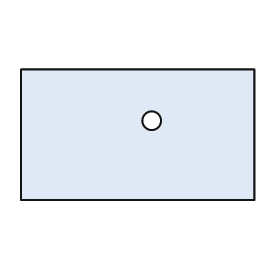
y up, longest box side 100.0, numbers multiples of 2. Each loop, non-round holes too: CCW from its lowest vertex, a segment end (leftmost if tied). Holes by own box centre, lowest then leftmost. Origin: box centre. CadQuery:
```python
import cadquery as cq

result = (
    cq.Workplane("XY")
    .moveTo(-50.0, -28.0)
    .lineTo(50.0, -28.0)
    .lineTo(50.0, 28.0)
    .lineTo(-50.0, 28.0)
    .close()
    .moveTo(6.0, 6.0)
    .circle(4.0)
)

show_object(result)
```